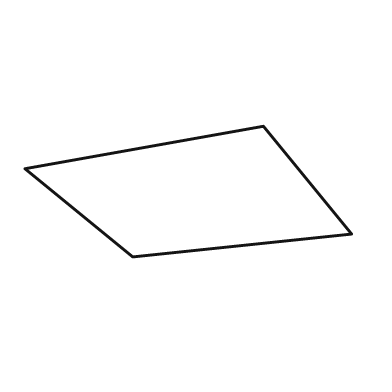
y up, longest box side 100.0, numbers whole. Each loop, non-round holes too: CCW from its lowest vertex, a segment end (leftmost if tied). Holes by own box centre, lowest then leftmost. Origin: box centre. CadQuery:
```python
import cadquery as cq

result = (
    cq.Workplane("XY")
    .moveTo(-17.0, -20.0)
    .lineTo(50.0, -13.0)
    .lineTo(23.0, 20.0)
    .lineTo(-50.0, 7.0)
    .close()
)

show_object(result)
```